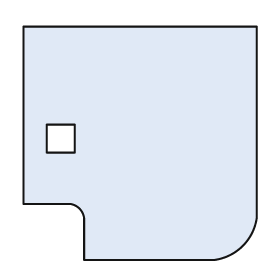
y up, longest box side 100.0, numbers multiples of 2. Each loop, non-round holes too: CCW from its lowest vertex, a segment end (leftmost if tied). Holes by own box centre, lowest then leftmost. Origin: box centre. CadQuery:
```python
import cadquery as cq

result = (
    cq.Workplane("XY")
    .moveTo(-24.0, -50.0)
    .lineTo(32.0, -50.0)
    .threePointArc((44.0, -44.0), (50.0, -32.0))
    .lineTo(50.0, 50.0)
    .lineTo(-50.0, 50.0)
    .lineTo(-50.0, -26.0)
    .lineTo(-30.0, -26.0)
    .threePointArc((-26.0, -28.0), (-24.0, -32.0))
    .close()
    .moveTo(-40.0, -4.0)
    .lineTo(-28.0, -4.0)
    .lineTo(-28.0, 8.0)
    .lineTo(-40.0, 8.0)
    .close()
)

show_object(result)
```